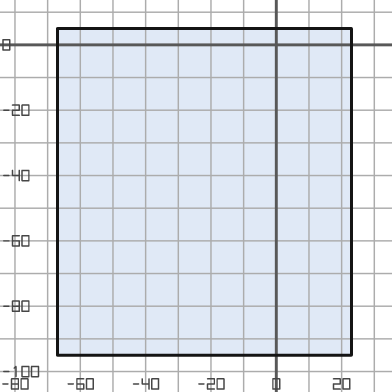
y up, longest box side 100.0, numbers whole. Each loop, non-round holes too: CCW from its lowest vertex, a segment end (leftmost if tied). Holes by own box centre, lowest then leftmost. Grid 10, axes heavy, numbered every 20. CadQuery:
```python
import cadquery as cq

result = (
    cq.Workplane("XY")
    .moveTo(-67.0, -95.0)
    .lineTo(23.0, -95.0)
    .lineTo(23.0, 5.0)
    .lineTo(-67.0, 5.0)
    .close()
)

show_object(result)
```